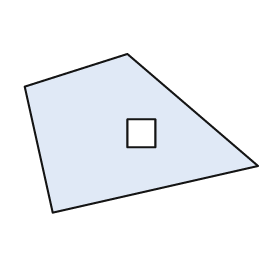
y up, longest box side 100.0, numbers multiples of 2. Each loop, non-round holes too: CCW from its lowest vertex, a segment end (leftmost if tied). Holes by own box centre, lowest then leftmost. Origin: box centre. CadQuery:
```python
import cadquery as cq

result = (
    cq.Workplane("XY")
    .moveTo(-38.0, -34.0)
    .lineTo(50.0, -14.0)
    .lineTo(-6.0, 34.0)
    .lineTo(-50.0, 20.0)
    .close()
    .moveTo(-6.0, -6.0)
    .lineTo(6.0, -6.0)
    .lineTo(6.0, 6.0)
    .lineTo(-6.0, 6.0)
    .close()
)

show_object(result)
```